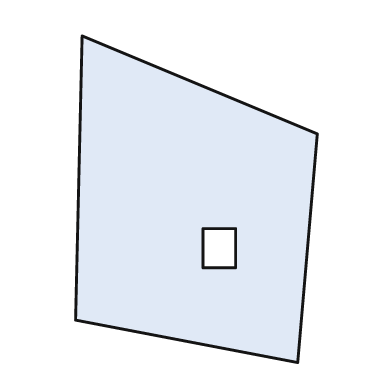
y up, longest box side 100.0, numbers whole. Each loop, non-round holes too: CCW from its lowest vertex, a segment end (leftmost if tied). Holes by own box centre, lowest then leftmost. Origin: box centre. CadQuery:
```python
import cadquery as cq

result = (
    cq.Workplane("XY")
    .moveTo(31.0, -50.0)
    .lineTo(37.0, 20.0)
    .lineTo(-35.0, 50.0)
    .lineTo(-37.0, -37.0)
    .close()
    .moveTo(2.0, -21.0)
    .lineTo(12.0, -21.0)
    .lineTo(12.0, -9.0)
    .lineTo(2.0, -9.0)
    .close()
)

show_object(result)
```